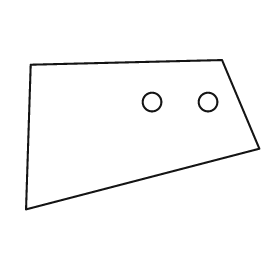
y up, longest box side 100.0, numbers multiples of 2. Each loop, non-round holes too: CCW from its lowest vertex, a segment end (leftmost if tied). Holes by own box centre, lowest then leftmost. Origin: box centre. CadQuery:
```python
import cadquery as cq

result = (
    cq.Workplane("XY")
    .moveTo(-50.0, -32.0)
    .lineTo(50.0, -6.0)
    .lineTo(34.0, 32.0)
    .lineTo(-48.0, 30.0)
    .close()
    .moveTo(4.0, 14.0)
    .circle(4.0)
    .moveTo(28.0, 14.0)
    .circle(4.0)
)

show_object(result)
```